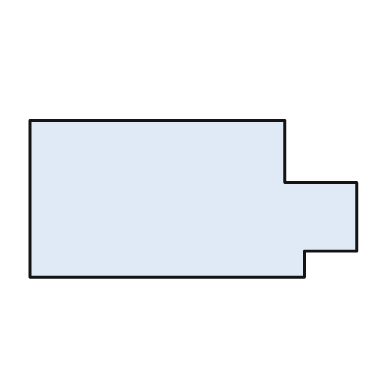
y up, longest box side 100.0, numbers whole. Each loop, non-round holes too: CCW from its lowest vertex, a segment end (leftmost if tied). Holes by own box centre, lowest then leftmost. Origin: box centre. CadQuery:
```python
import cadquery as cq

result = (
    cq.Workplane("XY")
    .moveTo(-50.0, -24.0)
    .lineTo(34.0, -24.0)
    .lineTo(34.0, -16.0)
    .lineTo(50.0, -16.0)
    .lineTo(50.0, 5.0)
    .lineTo(28.0, 5.0)
    .lineTo(28.0, 24.0)
    .lineTo(-50.0, 24.0)
    .close()
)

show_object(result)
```